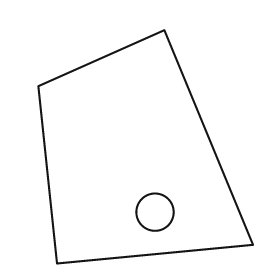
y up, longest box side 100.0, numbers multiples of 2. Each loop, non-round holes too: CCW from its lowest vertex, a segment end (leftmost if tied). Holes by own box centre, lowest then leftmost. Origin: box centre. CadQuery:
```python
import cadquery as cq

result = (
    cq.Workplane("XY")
    .moveTo(-38.0, -50.0)
    .lineTo(46.0, -42.0)
    .lineTo(8.0, 50.0)
    .lineTo(-46.0, 26.0)
    .close()
    .moveTo(4.0, -28.0)
    .circle(8.0)
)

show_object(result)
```